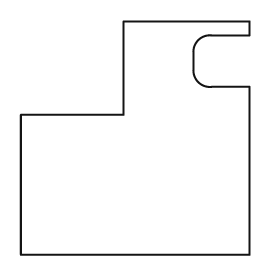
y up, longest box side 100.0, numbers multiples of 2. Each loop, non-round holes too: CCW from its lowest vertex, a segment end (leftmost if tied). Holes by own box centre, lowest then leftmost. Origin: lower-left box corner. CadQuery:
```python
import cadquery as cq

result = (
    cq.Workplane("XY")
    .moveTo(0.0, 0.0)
    .lineTo(98.0, 0.0)
    .lineTo(98.0, 72.0)
    .lineTo(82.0, 72.0)
    .threePointArc((76.0, 74.0), (74.0, 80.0))
    .lineTo(74.0, 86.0)
    .threePointArc((76.0, 92.0), (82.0, 94.0))
    .lineTo(98.0, 94.0)
    .lineTo(98.0, 100.0)
    .lineTo(44.0, 100.0)
    .lineTo(44.0, 60.0)
    .lineTo(0.0, 60.0)
    .close()
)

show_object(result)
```